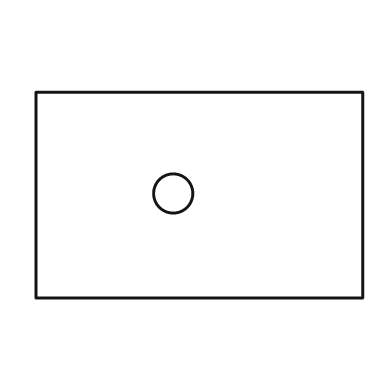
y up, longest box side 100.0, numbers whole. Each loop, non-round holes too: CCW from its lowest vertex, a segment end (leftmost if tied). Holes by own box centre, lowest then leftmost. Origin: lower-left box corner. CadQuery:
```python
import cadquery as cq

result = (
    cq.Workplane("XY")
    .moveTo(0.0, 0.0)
    .lineTo(100.0, 0.0)
    .lineTo(100.0, 63.0)
    .lineTo(0.0, 63.0)
    .close()
    .moveTo(42.0, 32.0)
    .circle(6.0)
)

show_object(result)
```